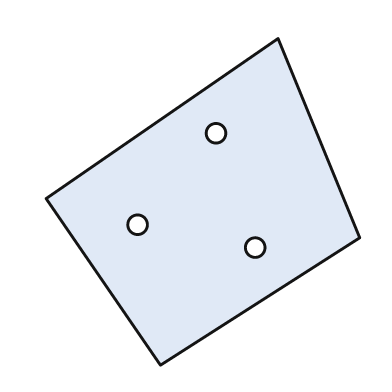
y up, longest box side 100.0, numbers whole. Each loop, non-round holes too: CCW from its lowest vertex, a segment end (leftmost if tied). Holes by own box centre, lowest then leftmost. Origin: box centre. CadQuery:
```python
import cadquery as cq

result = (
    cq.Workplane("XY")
    .moveTo(-13.0, -50.0)
    .lineTo(48.0, -11.0)
    .lineTo(23.0, 50.0)
    .lineTo(-48.0, 1.0)
    .close()
    .moveTo(16.0, -14.0)
    .circle(3.0)
    .moveTo(-20.0, -7.0)
    .circle(3.0)
    .moveTo(4.0, 21.0)
    .circle(3.0)
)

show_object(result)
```